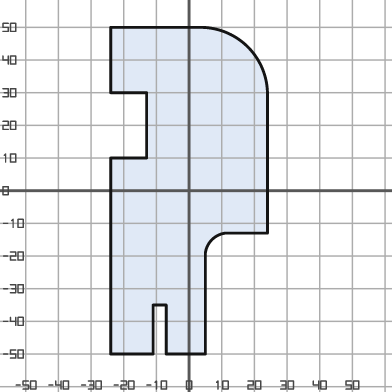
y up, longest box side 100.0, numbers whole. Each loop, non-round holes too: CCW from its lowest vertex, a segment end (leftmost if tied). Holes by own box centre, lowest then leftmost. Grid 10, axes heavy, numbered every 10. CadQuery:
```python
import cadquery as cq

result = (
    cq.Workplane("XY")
    .moveTo(-24.0, -50.0)
    .lineTo(-11.0, -50.0)
    .lineTo(-11.0, -35.0)
    .lineTo(-7.0, -35.0)
    .lineTo(-7.0, -50.0)
    .lineTo(5.0, -50.0)
    .lineTo(5.0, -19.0)
    .threePointArc((7.0, -15.0), (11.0, -13.0))
    .lineTo(24.0, -13.0)
    .lineTo(24.0, 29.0)
    .threePointArc((18.0, 44.0), (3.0, 50.0))
    .lineTo(-24.0, 50.0)
    .lineTo(-24.0, 30.0)
    .lineTo(-13.0, 30.0)
    .lineTo(-13.0, 10.0)
    .lineTo(-24.0, 10.0)
    .close()
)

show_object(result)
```